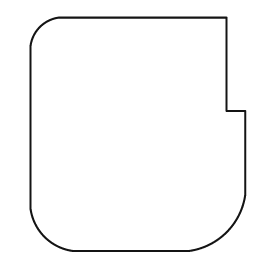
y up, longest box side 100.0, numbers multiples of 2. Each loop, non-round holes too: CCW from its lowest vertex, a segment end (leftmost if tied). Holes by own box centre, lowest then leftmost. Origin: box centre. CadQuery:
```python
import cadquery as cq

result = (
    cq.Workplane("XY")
    .moveTo(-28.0, -50.0)
    .lineTo(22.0, -50.0)
    .threePointArc((38.0, -42.0), (46.0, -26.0))
    .lineTo(46.0, 10.0)
    .lineTo(38.0, 10.0)
    .lineTo(38.0, 50.0)
    .lineTo(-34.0, 50.0)
    .threePointArc((-42.0, 46.0), (-46.0, 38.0))
    .lineTo(-46.0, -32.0)
    .threePointArc((-40.0, -44.0), (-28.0, -50.0))
    .close()
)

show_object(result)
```